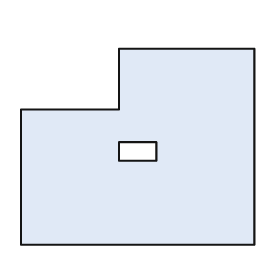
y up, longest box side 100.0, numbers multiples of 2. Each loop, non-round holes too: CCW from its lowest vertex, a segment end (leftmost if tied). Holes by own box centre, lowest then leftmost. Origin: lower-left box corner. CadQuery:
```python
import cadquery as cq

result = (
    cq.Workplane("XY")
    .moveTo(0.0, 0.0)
    .lineTo(100.0, 0.0)
    .lineTo(100.0, 84.0)
    .lineTo(42.0, 84.0)
    .lineTo(42.0, 58.0)
    .lineTo(0.0, 58.0)
    .close()
    .moveTo(42.0, 36.0)
    .lineTo(58.0, 36.0)
    .lineTo(58.0, 44.0)
    .lineTo(42.0, 44.0)
    .close()
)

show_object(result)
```